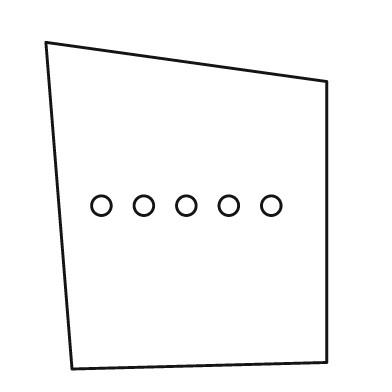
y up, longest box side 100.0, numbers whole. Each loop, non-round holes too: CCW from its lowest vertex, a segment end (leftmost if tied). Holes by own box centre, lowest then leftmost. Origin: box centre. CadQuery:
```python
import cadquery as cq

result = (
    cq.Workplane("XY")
    .moveTo(-35.0, -50.0)
    .lineTo(43.0, -48.0)
    .lineTo(43.0, 38.0)
    .lineTo(-43.0, 50.0)
    .close()
    .moveTo(-26.0, 0.0)
    .circle(3.0)
    .moveTo(-13.0, 0.0)
    .circle(3.0)
    .moveTo(0.0, 0.0)
    .circle(3.0)
    .moveTo(13.0, 0.0)
    .circle(3.0)
    .moveTo(26.0, 0.0)
    .circle(3.0)
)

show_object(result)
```